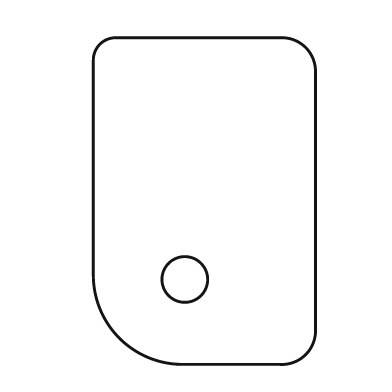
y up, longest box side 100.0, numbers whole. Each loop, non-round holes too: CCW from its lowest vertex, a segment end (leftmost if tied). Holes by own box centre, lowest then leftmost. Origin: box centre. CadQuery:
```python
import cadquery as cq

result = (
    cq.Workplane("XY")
    .moveTo(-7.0, -50.0)
    .lineTo(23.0, -50.0)
    .threePointArc((31.0, -47.0), (34.0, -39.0))
    .lineTo(34.0, 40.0)
    .threePointArc((31.0, 47.0), (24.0, 50.0))
    .lineTo(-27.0, 50.0)
    .threePointArc((-32.0, 48.0), (-34.0, 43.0))
    .lineTo(-34.0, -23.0)
    .threePointArc((-26.0, -42.0), (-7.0, -50.0))
    .close()
    .moveTo(-6.0, -24.0)
    .circle(7.0)
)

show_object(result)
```